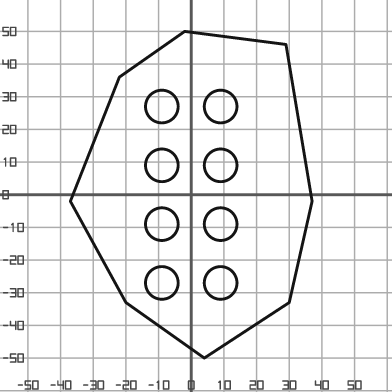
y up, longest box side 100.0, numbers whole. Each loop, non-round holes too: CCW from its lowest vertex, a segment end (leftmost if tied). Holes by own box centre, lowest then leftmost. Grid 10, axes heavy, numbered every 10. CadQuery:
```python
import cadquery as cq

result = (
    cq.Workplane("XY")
    .moveTo(4.0, -50.0)
    .lineTo(30.0, -33.0)
    .lineTo(37.0, -2.0)
    .lineTo(29.0, 46.0)
    .lineTo(-2.0, 50.0)
    .lineTo(-22.0, 36.0)
    .lineTo(-37.0, -2.0)
    .lineTo(-20.0, -33.0)
    .close()
    .moveTo(-9.0, -27.0)
    .circle(5.0)
    .moveTo(9.0, -27.0)
    .circle(5.0)
    .moveTo(-9.0, -9.0)
    .circle(5.0)
    .moveTo(9.0, -9.0)
    .circle(5.0)
    .moveTo(-9.0, 9.0)
    .circle(5.0)
    .moveTo(9.0, 9.0)
    .circle(5.0)
    .moveTo(-9.0, 27.0)
    .circle(5.0)
    .moveTo(9.0, 27.0)
    .circle(5.0)
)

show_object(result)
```